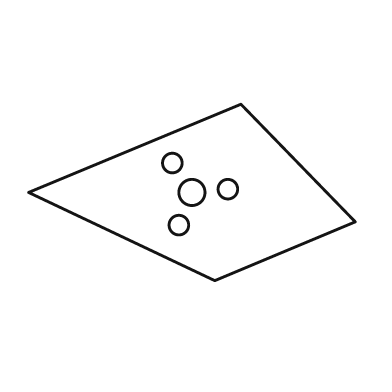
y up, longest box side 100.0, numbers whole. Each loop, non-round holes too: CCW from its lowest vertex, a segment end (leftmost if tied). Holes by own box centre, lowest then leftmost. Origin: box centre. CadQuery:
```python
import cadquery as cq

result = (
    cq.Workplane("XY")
    .moveTo(7.0, -27.0)
    .lineTo(50.0, -9.0)
    .lineTo(15.0, 27.0)
    .lineTo(-50.0, 0.0)
    .close()
    .moveTo(-4.0, -10.0)
    .circle(3.0)
    .moveTo(0.0, 0.0)
    .circle(4.0)
    .moveTo(11.0, 1.0)
    .circle(3.0)
    .moveTo(-6.0, 9.0)
    .circle(3.0)
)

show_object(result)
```